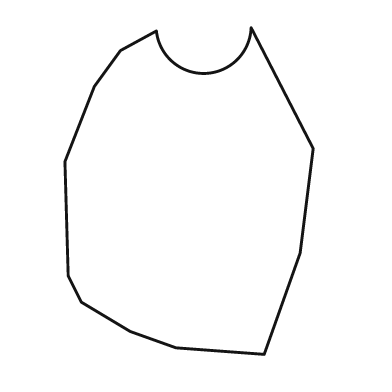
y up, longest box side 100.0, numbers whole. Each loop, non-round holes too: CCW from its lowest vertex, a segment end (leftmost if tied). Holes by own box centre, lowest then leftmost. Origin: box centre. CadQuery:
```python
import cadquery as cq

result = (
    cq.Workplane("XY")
    .moveTo(23.0, -50.0)
    .lineTo(34.0, -19.0)
    .lineTo(38.0, 13.0)
    .lineTo(19.0, 50.0)
    .threePointArc((5.0, 36.0), (-10.0, 49.0))
    .lineTo(-21.0, 43.0)
    .lineTo(-29.0, 32.0)
    .lineTo(-38.0, 9.0)
    .lineTo(-37.0, -26.0)
    .lineTo(-33.0, -34.0)
    .lineTo(-18.0, -43.0)
    .lineTo(-4.0, -48.0)
    .close()
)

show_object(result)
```